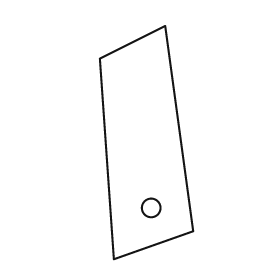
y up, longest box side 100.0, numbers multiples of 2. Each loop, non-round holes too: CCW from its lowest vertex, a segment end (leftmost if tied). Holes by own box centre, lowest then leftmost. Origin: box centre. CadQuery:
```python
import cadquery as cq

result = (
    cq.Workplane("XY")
    .moveTo(-14.0, -50.0)
    .lineTo(20.0, -38.0)
    .lineTo(8.0, 50.0)
    .lineTo(-20.0, 36.0)
    .close()
    .moveTo(2.0, -28.0)
    .circle(4.0)
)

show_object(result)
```